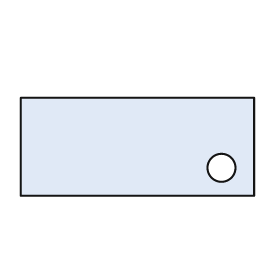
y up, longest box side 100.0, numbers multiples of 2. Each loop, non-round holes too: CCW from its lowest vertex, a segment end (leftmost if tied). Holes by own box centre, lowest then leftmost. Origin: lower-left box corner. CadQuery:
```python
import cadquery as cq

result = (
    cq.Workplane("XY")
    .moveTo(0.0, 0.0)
    .lineTo(100.0, 0.0)
    .lineTo(100.0, 42.0)
    .lineTo(0.0, 42.0)
    .close()
    .moveTo(86.0, 12.0)
    .circle(6.0)
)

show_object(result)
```